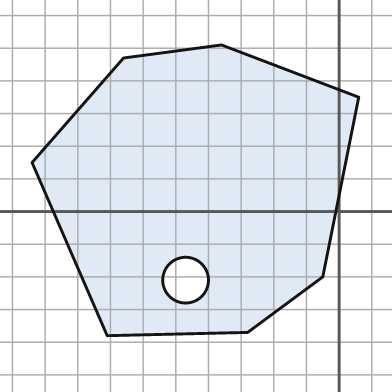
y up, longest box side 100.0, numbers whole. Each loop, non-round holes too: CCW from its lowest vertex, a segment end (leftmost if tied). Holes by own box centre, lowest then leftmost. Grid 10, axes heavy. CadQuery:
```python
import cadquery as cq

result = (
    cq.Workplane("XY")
    .moveTo(-71.0, -38.0)
    .lineTo(-28.0, -37.0)
    .lineTo(-5.0, -20.0)
    .lineTo(6.0, 35.0)
    .lineTo(-36.0, 51.0)
    .lineTo(-66.0, 47.0)
    .lineTo(-94.0, 15.0)
    .close()
    .moveTo(-47.0, -21.0)
    .circle(7.0)
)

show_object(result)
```